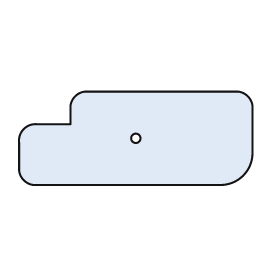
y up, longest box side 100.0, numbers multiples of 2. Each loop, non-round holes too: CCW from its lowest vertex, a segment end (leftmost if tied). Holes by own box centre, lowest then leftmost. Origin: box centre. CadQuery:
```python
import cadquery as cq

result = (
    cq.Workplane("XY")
    .moveTo(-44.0, -20.0)
    .lineTo(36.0, -20.0)
    .threePointArc((46.0, -16.0), (50.0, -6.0))
    .lineTo(50.0, 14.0)
    .threePointArc((48.0, 18.0), (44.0, 20.0))
    .lineTo(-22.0, 20.0)
    .threePointArc((-26.0, 18.0), (-28.0, 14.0))
    .lineTo(-28.0, 6.0)
    .lineTo(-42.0, 6.0)
    .threePointArc((-48.0, 4.0), (-50.0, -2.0))
    .lineTo(-50.0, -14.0)
    .threePointArc((-48.0, -18.0), (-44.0, -20.0))
    .close()
    .moveTo(0.0, 0.0)
    .circle(2.0)
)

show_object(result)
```